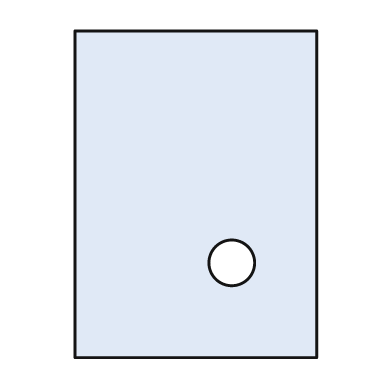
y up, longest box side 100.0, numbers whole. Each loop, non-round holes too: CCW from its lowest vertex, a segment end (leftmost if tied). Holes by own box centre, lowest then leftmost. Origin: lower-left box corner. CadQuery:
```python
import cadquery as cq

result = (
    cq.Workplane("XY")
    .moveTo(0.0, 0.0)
    .lineTo(74.0, 0.0)
    .lineTo(74.0, 100.0)
    .lineTo(0.0, 100.0)
    .close()
    .moveTo(48.0, 29.0)
    .circle(7.0)
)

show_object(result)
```